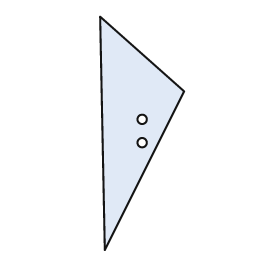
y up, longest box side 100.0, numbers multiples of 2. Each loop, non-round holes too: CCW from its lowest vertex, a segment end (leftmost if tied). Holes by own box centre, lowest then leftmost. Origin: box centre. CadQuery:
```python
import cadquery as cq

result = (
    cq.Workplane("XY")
    .moveTo(-16.0, -50.0)
    .lineTo(18.0, 18.0)
    .lineTo(-18.0, 50.0)
    .close()
    .moveTo(0.0, -4.0)
    .circle(2.0)
    .moveTo(0.0, 6.0)
    .circle(2.0)
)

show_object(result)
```